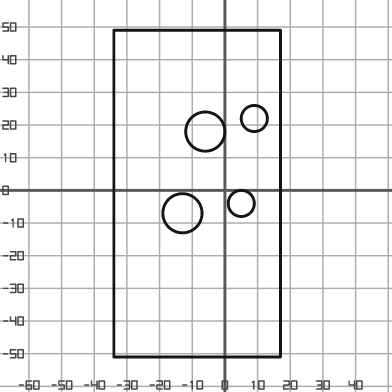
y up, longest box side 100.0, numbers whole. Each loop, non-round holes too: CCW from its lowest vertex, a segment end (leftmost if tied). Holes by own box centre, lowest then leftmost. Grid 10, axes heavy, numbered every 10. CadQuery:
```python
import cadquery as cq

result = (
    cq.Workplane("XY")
    .moveTo(-34.0, -51.0)
    .lineTo(17.0, -51.0)
    .lineTo(17.0, 49.0)
    .lineTo(-34.0, 49.0)
    .close()
    .moveTo(-13.0, -7.0)
    .circle(6.0)
    .moveTo(5.0, -4.0)
    .circle(4.0)
    .moveTo(-6.0, 18.0)
    .circle(6.0)
    .moveTo(9.0, 22.0)
    .circle(4.0)
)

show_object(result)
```